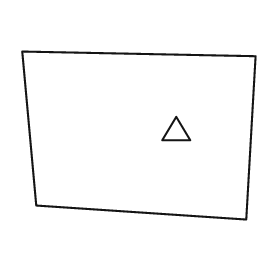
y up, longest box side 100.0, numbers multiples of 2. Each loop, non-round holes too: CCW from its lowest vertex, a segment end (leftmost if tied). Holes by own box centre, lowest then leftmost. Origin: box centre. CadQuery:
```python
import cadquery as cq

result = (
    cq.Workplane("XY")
    .moveTo(46.0, -36.0)
    .lineTo(50.0, 34.0)
    .lineTo(-50.0, 36.0)
    .lineTo(-44.0, -30.0)
    .close()
    .moveTo(10.0, -2.0)
    .lineTo(22.0, -2.0)
    .lineTo(16.0, 8.0)
    .close()
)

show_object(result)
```